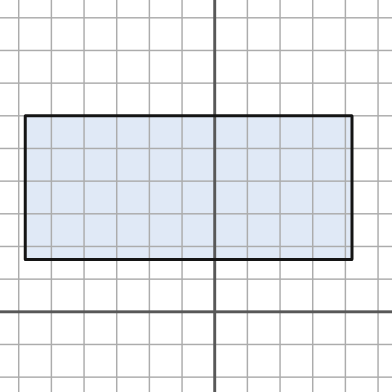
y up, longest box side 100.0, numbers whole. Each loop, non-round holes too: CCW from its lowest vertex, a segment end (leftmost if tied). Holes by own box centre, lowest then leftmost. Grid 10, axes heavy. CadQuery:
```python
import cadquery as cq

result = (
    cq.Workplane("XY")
    .moveTo(-58.0, 16.0)
    .lineTo(42.0, 16.0)
    .lineTo(42.0, 60.0)
    .lineTo(-58.0, 60.0)
    .close()
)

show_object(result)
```